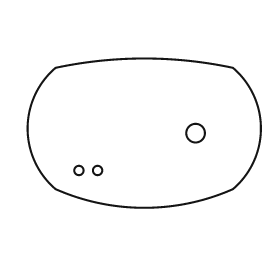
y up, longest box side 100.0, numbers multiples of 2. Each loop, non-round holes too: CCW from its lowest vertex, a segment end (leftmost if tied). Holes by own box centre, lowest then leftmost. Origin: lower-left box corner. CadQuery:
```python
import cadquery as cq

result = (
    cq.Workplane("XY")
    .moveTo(12.0, 8.0)
    .threePointArc((50.0, 0.0), (88.0, 8.0))
    .threePointArc((100.0, 34.0), (88.0, 60.0))
    .threePointArc((50.0, 64.0), (12.0, 60.0))
    .threePointArc((0.0, 34.0), (12.0, 8.0))
    .close()
    .moveTo(22.0, 16.0)
    .circle(2.0)
    .moveTo(30.0, 16.0)
    .circle(2.0)
    .moveTo(72.0, 32.0)
    .circle(4.0)
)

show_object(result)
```